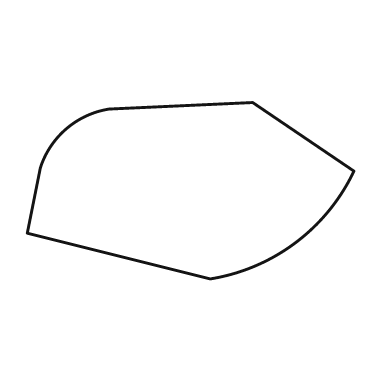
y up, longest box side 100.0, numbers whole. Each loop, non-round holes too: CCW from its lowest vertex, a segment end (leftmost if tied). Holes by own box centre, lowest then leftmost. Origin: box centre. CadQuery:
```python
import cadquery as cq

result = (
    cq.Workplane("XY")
    .moveTo(6.0, -27.0)
    .threePointArc((32.0, -16.0), (50.0, 6.0))
    .lineTo(19.0, 27.0)
    .lineTo(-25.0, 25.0)
    .threePointArc((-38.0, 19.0), (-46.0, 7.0))
    .lineTo(-50.0, -13.0)
    .close()
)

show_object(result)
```